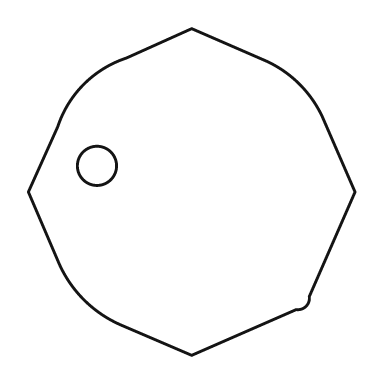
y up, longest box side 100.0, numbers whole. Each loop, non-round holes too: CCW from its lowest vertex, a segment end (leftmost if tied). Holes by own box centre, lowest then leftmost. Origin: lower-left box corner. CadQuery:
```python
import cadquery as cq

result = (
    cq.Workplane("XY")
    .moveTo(50.0, 0.0)
    .lineTo(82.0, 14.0)
    .threePointArc((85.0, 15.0), (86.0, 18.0))
    .lineTo(100.0, 50.0)
    .lineTo(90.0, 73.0)
    .threePointArc((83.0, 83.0), (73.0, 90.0))
    .lineTo(50.0, 100.0)
    .lineTo(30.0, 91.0)
    .threePointArc((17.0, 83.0), (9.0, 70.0))
    .lineTo(0.0, 50.0)
    .lineTo(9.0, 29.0)
    .threePointArc((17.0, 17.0), (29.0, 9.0))
    .close()
    .moveTo(21.0, 58.0)
    .circle(6.0)
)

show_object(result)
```